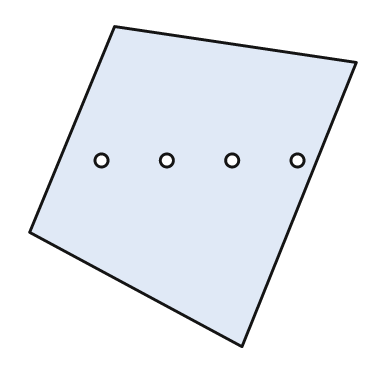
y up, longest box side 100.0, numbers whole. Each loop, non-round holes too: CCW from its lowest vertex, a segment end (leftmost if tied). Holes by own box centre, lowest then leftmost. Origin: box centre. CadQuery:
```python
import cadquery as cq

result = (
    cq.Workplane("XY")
    .moveTo(15.0, -49.0)
    .lineTo(50.0, 38.0)
    .lineTo(-24.0, 49.0)
    .lineTo(-50.0, -14.0)
    .close()
    .moveTo(-28.0, 8.0)
    .circle(2.0)
    .moveTo(-8.0, 8.0)
    .circle(2.0)
    .moveTo(12.0, 8.0)
    .circle(2.0)
    .moveTo(32.0, 8.0)
    .circle(2.0)
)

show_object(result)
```